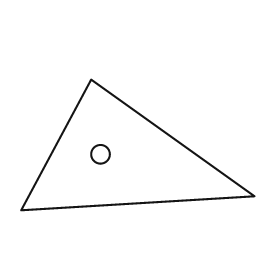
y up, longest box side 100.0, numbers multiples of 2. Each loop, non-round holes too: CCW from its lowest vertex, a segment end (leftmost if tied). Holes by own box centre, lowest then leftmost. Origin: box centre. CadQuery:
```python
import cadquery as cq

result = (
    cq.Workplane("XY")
    .moveTo(-50.0, -28.0)
    .lineTo(50.0, -22.0)
    .lineTo(-20.0, 28.0)
    .close()
    .moveTo(-16.0, -4.0)
    .circle(4.0)
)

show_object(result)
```